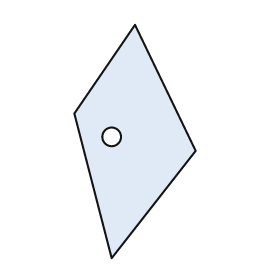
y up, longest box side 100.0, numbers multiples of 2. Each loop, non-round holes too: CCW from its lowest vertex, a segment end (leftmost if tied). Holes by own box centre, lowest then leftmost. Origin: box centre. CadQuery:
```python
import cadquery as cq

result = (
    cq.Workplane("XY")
    .moveTo(-10.0, -50.0)
    .lineTo(26.0, -4.0)
    .lineTo(0.0, 50.0)
    .lineTo(-26.0, 12.0)
    .close()
    .moveTo(-10.0, 2.0)
    .circle(4.0)
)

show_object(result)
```